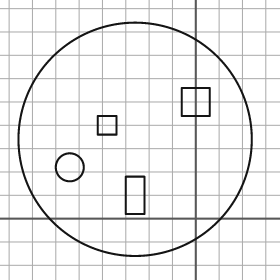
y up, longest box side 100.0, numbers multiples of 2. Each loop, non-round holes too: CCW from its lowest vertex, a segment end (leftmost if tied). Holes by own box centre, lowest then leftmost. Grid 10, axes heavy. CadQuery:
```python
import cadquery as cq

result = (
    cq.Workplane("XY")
    .moveTo(-26.0, 34.0)
    .circle(50.0)
    .moveTo(-30.0, 2.0)
    .lineTo(-22.0, 2.0)
    .lineTo(-22.0, 18.0)
    .lineTo(-30.0, 18.0)
    .close()
    .moveTo(-54.0, 22.0)
    .circle(6.0)
    .moveTo(-42.0, 36.0)
    .lineTo(-34.0, 36.0)
    .lineTo(-34.0, 44.0)
    .lineTo(-42.0, 44.0)
    .close()
    .moveTo(-6.0, 44.0)
    .lineTo(6.0, 44.0)
    .lineTo(6.0, 56.0)
    .lineTo(-6.0, 56.0)
    .close()
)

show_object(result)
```